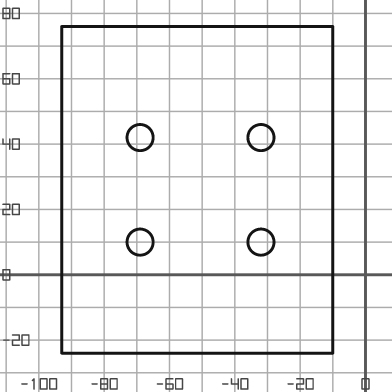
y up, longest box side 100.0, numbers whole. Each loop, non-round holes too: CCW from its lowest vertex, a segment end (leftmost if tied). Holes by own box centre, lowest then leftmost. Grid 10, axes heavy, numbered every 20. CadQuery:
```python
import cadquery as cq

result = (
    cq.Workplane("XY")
    .moveTo(-93.0, -24.0)
    .lineTo(-10.0, -24.0)
    .lineTo(-10.0, 76.0)
    .lineTo(-93.0, 76.0)
    .close()
    .moveTo(-69.0, 10.0)
    .circle(4.0)
    .moveTo(-32.0, 10.0)
    .circle(4.0)
    .moveTo(-69.0, 42.0)
    .circle(4.0)
    .moveTo(-32.0, 42.0)
    .circle(4.0)
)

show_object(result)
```